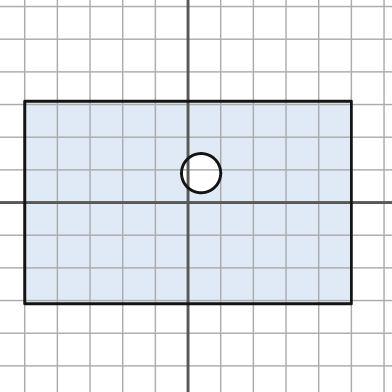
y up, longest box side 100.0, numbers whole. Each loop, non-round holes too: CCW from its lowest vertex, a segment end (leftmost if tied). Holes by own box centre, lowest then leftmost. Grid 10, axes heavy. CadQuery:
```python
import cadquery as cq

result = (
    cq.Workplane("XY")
    .moveTo(-50.0, -31.0)
    .lineTo(50.0, -31.0)
    .lineTo(50.0, 31.0)
    .lineTo(-50.0, 31.0)
    .close()
    .moveTo(4.0, 9.0)
    .circle(6.0)
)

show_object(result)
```